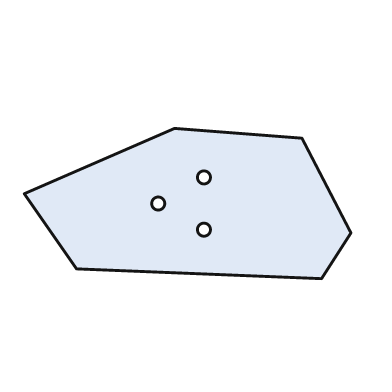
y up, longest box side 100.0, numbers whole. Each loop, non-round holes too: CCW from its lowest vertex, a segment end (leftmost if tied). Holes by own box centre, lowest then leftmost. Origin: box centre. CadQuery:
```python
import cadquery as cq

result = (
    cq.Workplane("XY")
    .moveTo(41.0, -23.0)
    .lineTo(50.0, -9.0)
    .lineTo(35.0, 20.0)
    .lineTo(-4.0, 23.0)
    .lineTo(-50.0, 3.0)
    .lineTo(-34.0, -20.0)
    .close()
    .moveTo(5.0, -8.0)
    .circle(2.0)
    .moveTo(-9.0, 0.0)
    .circle(2.0)
    .moveTo(5.0, 8.0)
    .circle(2.0)
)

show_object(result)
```